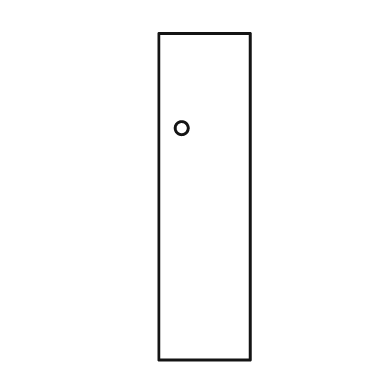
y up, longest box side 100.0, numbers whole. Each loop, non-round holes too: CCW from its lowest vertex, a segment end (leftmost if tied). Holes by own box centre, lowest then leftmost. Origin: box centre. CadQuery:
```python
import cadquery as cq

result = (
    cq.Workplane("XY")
    .moveTo(-14.0, -50.0)
    .lineTo(14.0, -50.0)
    .lineTo(14.0, 50.0)
    .lineTo(-14.0, 50.0)
    .close()
    .moveTo(-7.0, 21.0)
    .circle(2.0)
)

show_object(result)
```